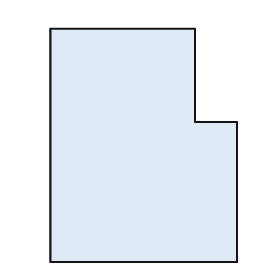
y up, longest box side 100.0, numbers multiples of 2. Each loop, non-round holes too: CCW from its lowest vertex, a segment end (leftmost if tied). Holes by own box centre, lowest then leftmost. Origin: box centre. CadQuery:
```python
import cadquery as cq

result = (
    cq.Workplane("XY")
    .moveTo(-40.0, -50.0)
    .lineTo(40.0, -50.0)
    .lineTo(40.0, 10.0)
    .lineTo(22.0, 10.0)
    .lineTo(22.0, 50.0)
    .lineTo(-40.0, 50.0)
    .close()
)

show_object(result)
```